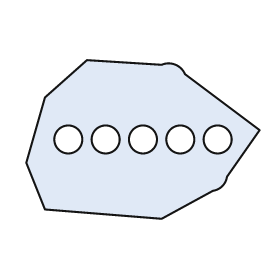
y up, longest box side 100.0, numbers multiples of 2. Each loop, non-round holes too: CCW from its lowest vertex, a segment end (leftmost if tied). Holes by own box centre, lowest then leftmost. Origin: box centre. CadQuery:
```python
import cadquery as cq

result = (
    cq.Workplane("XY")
    .moveTo(8.0, -34.0)
    .lineTo(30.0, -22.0)
    .threePointArc((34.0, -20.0), (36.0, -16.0))
    .lineTo(50.0, 4.0)
    .lineTo(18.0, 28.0)
    .threePointArc((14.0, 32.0), (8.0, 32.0))
    .lineTo(-24.0, 34.0)
    .lineTo(-42.0, 18.0)
    .lineTo(-50.0, -10.0)
    .lineTo(-42.0, -30.0)
    .close()
    .moveTo(-32.0, 0.0)
    .circle(6.0)
    .moveTo(-16.0, 0.0)
    .circle(6.0)
    .moveTo(0.0, 0.0)
    .circle(6.0)
    .moveTo(16.0, 0.0)
    .circle(6.0)
    .moveTo(32.0, 0.0)
    .circle(6.0)
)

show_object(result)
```